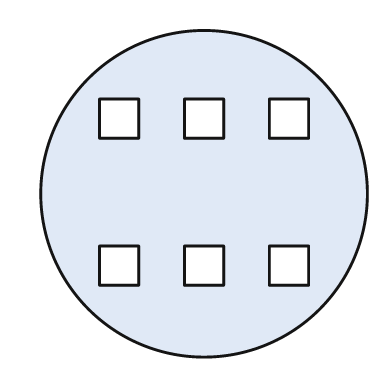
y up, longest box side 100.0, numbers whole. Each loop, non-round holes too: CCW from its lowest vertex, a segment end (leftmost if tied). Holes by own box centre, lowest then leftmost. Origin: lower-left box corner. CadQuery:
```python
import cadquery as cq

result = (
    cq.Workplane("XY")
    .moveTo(50.0, 50.0)
    .circle(50.0)
    .moveTo(18.0, 22.0)
    .lineTo(30.0, 22.0)
    .lineTo(30.0, 34.0)
    .lineTo(18.0, 34.0)
    .close()
    .moveTo(44.0, 22.0)
    .lineTo(56.0, 22.0)
    .lineTo(56.0, 34.0)
    .lineTo(44.0, 34.0)
    .close()
    .moveTo(70.0, 22.0)
    .lineTo(82.0, 22.0)
    .lineTo(82.0, 34.0)
    .lineTo(70.0, 34.0)
    .close()
    .moveTo(18.0, 67.0)
    .lineTo(30.0, 67.0)
    .lineTo(30.0, 79.0)
    .lineTo(18.0, 79.0)
    .close()
    .moveTo(44.0, 67.0)
    .lineTo(56.0, 67.0)
    .lineTo(56.0, 79.0)
    .lineTo(44.0, 79.0)
    .close()
    .moveTo(70.0, 67.0)
    .lineTo(82.0, 67.0)
    .lineTo(82.0, 79.0)
    .lineTo(70.0, 79.0)
    .close()
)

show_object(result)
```